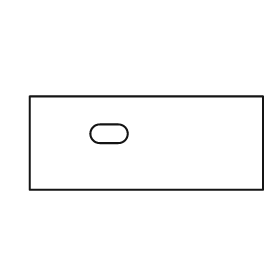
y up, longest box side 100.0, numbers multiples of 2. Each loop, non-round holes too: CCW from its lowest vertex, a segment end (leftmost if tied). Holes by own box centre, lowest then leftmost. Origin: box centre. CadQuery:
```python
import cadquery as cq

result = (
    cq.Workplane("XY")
    .moveTo(-50.0, -20.0)
    .lineTo(50.0, -20.0)
    .lineTo(50.0, 20.0)
    .lineTo(-50.0, 20.0)
    .close()
    .moveTo(-20.0, 0.0)
    .lineTo(-12.0, 0.0)
    .threePointArc((-8.0, 4.0), (-12.0, 8.0))
    .lineTo(-20.0, 8.0)
    .threePointArc((-24.0, 4.0), (-20.0, 0.0))
    .close()
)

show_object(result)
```